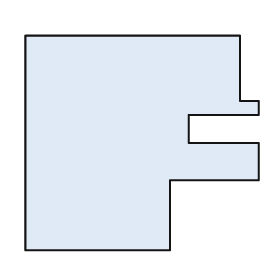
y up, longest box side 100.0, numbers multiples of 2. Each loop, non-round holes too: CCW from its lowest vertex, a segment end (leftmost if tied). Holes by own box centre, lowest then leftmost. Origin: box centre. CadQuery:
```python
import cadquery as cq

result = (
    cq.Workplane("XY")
    .moveTo(-50.0, -46.0)
    .lineTo(12.0, -46.0)
    .lineTo(12.0, -16.0)
    .lineTo(50.0, -16.0)
    .lineTo(50.0, 0.0)
    .lineTo(20.0, 0.0)
    .lineTo(20.0, 12.0)
    .lineTo(50.0, 12.0)
    .lineTo(50.0, 18.0)
    .lineTo(42.0, 18.0)
    .lineTo(42.0, 46.0)
    .lineTo(-50.0, 46.0)
    .close()
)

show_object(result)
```